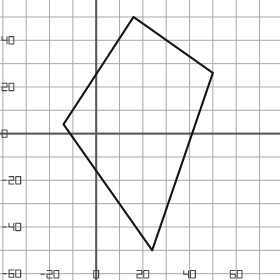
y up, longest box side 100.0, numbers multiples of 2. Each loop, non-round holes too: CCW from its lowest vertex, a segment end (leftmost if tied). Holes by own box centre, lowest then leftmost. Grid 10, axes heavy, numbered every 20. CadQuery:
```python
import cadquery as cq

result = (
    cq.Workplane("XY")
    .moveTo(24.0, -50.0)
    .lineTo(50.0, 26.0)
    .lineTo(16.0, 50.0)
    .lineTo(-14.0, 4.0)
    .close()
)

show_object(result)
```